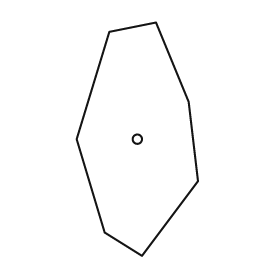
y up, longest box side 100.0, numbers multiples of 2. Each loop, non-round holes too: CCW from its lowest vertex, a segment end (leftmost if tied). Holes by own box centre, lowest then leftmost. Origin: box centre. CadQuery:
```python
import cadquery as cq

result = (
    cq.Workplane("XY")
    .moveTo(2.0, -50.0)
    .lineTo(26.0, -18.0)
    .lineTo(22.0, 16.0)
    .lineTo(8.0, 50.0)
    .lineTo(-12.0, 46.0)
    .lineTo(-26.0, 0.0)
    .lineTo(-14.0, -40.0)
    .close()
    .moveTo(0.0, 0.0)
    .circle(2.0)
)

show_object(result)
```